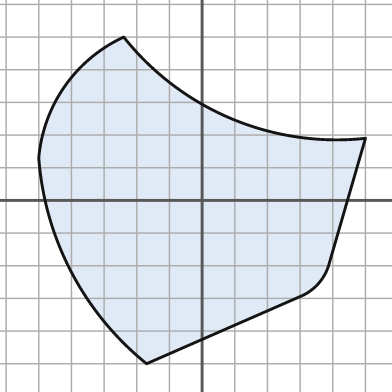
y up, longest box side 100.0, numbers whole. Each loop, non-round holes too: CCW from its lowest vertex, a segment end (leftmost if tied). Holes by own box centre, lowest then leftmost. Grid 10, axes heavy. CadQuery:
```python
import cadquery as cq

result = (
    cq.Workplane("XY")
    .moveTo(-17.0, -50.0)
    .lineTo(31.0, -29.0)
    .threePointArc((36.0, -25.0), (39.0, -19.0))
    .lineTo(50.0, 19.0)
    .threePointArc((9.0, 25.0), (-24.0, 50.0))
    .threePointArc((-42.0, 35.0), (-50.0, 13.0))
    .threePointArc((-40.0, -22.0), (-17.0, -50.0))
    .close()
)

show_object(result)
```